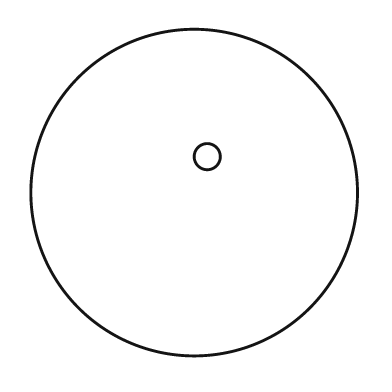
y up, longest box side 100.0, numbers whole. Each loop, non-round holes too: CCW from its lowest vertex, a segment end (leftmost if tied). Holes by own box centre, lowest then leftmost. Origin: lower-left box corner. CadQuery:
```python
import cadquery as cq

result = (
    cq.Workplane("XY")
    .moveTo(50.0, 50.0)
    .circle(50.0)
    .moveTo(54.0, 61.0)
    .circle(4.0)
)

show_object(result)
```